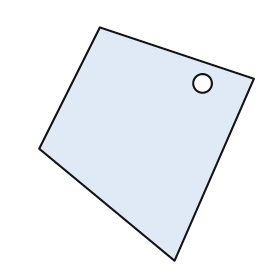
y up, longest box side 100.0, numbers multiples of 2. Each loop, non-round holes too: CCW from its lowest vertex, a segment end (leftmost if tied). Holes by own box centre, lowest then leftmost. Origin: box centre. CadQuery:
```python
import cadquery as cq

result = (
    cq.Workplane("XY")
    .moveTo(12.0, -50.0)
    .lineTo(46.0, 28.0)
    .lineTo(-20.0, 50.0)
    .lineTo(-46.0, -2.0)
    .close()
    .moveTo(24.0, 26.0)
    .circle(4.0)
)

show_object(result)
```